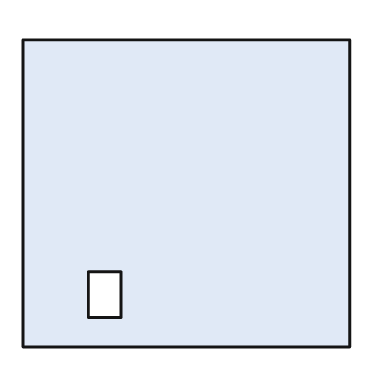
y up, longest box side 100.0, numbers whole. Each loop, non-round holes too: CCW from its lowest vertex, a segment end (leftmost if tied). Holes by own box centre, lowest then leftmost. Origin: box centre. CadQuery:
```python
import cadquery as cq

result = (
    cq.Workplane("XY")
    .moveTo(-50.0, -47.0)
    .lineTo(50.0, -47.0)
    .lineTo(50.0, 47.0)
    .lineTo(-50.0, 47.0)
    .close()
    .moveTo(-30.0, -38.0)
    .lineTo(-20.0, -38.0)
    .lineTo(-20.0, -24.0)
    .lineTo(-30.0, -24.0)
    .close()
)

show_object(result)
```